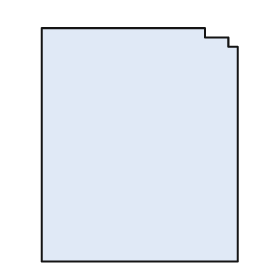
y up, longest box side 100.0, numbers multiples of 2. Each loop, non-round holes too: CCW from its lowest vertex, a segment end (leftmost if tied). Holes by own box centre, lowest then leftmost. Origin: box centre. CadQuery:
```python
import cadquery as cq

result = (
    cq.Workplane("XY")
    .moveTo(-42.0, -50.0)
    .lineTo(42.0, -50.0)
    .lineTo(42.0, 42.0)
    .lineTo(38.0, 42.0)
    .lineTo(38.0, 46.0)
    .lineTo(28.0, 46.0)
    .lineTo(28.0, 50.0)
    .lineTo(-42.0, 50.0)
    .close()
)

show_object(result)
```